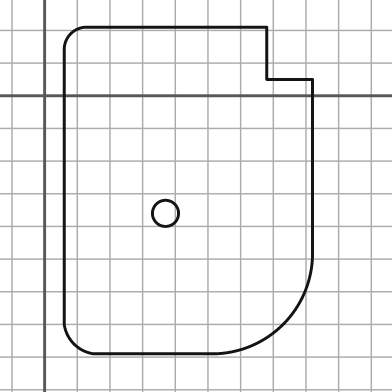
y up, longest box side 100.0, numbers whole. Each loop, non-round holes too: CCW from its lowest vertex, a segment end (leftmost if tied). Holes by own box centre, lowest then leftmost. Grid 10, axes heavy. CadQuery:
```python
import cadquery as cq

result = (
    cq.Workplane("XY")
    .moveTo(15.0, -79.0)
    .lineTo(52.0, -79.0)
    .threePointArc((73.0, -70.0), (82.0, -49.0))
    .lineTo(82.0, 5.0)
    .lineTo(68.0, 5.0)
    .lineTo(68.0, 21.0)
    .lineTo(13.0, 21.0)
    .threePointArc((8.0, 19.0), (6.0, 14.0))
    .lineTo(6.0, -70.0)
    .threePointArc((9.0, -76.0), (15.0, -79.0))
    .close()
    .moveTo(37.0, -36.0)
    .circle(4.0)
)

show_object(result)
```